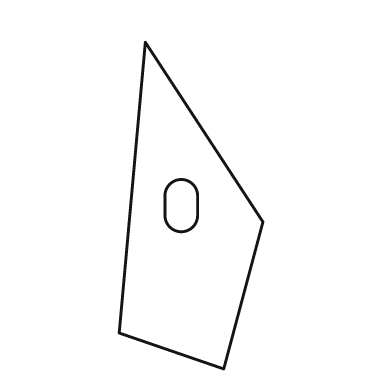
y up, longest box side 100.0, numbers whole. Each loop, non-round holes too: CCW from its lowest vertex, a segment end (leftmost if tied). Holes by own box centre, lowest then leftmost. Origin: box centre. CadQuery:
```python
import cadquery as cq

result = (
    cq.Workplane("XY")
    .moveTo(10.0, -50.0)
    .lineTo(22.0, -5.0)
    .lineTo(-14.0, 50.0)
    .lineTo(-22.0, -39.0)
    .close()
    .moveTo(-8.0, -3.0)
    .threePointArc((-3.0, -8.0), (2.0, -3.0))
    .lineTo(2.0, 3.0)
    .threePointArc((-3.0, 8.0), (-8.0, 3.0))
    .close()
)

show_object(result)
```